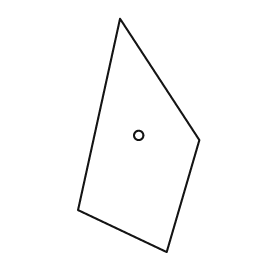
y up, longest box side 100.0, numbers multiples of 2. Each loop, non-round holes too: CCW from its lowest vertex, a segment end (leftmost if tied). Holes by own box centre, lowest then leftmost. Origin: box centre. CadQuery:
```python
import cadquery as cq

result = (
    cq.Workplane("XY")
    .moveTo(12.0, -50.0)
    .lineTo(26.0, -2.0)
    .lineTo(-8.0, 50.0)
    .lineTo(-26.0, -32.0)
    .close()
    .moveTo(0.0, 0.0)
    .circle(2.0)
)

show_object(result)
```